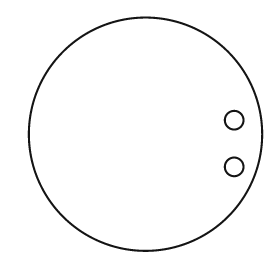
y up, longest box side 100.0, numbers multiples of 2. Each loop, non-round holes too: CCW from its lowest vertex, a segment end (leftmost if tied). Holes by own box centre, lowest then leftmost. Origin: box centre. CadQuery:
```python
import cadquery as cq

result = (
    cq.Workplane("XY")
    .moveTo(0.0, 0.0)
    .circle(50.0)
    .moveTo(38.0, -14.0)
    .circle(4.0)
    .moveTo(38.0, 6.0)
    .circle(4.0)
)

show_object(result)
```